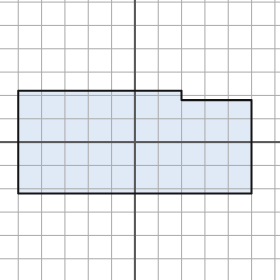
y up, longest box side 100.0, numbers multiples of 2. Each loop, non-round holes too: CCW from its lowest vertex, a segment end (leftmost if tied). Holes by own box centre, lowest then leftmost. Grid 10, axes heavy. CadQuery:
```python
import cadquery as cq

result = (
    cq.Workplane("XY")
    .moveTo(-50.0, -22.0)
    .lineTo(50.0, -22.0)
    .lineTo(50.0, 18.0)
    .lineTo(20.0, 18.0)
    .lineTo(20.0, 22.0)
    .lineTo(-50.0, 22.0)
    .close()
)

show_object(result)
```